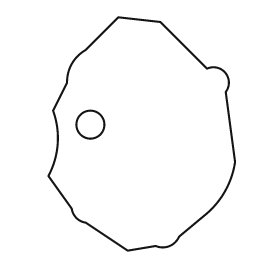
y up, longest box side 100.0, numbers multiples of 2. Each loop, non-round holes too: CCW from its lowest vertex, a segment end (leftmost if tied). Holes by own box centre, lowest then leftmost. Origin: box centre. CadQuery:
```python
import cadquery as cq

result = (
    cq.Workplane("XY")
    .moveTo(-6.0, -50.0)
    .lineTo(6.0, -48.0)
    .threePointArc((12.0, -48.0), (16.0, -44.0))
    .lineTo(28.0, -34.0)
    .threePointArc((36.0, -24.0), (40.0, -12.0))
    .lineTo(36.0, 18.0)
    .threePointArc((36.0, 26.0), (28.0, 28.0))
    .lineTo(8.0, 48.0)
    .lineTo(-10.0, 50.0)
    .lineTo(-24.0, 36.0)
    .threePointArc((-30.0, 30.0), (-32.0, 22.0))
    .lineTo(-38.0, 10.0)
    .threePointArc((-36.0, -4.0), (-40.0, -18.0))
    .lineTo(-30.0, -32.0)
    .threePointArc((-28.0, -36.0), (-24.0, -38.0))
    .close()
    .moveTo(-22.0, 4.0)
    .circle(6.0)
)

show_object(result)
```